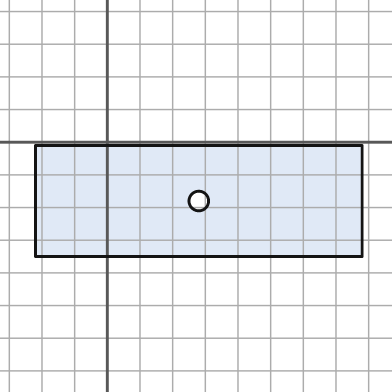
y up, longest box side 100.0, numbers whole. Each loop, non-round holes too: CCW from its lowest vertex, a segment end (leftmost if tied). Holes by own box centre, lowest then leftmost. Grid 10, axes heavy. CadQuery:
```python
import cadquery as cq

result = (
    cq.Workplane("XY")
    .moveTo(-22.0, -35.0)
    .lineTo(78.0, -35.0)
    .lineTo(78.0, -1.0)
    .lineTo(-22.0, -1.0)
    .close()
    .moveTo(28.0, -18.0)
    .circle(3.0)
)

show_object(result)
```